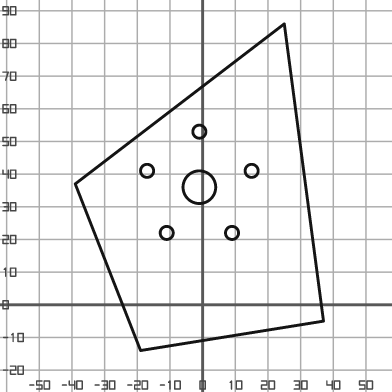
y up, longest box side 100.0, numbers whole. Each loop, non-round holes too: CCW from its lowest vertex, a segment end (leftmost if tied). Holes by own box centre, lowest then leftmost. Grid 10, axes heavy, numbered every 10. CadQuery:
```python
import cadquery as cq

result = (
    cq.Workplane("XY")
    .moveTo(-19.0, -14.0)
    .lineTo(37.0, -5.0)
    .lineTo(25.0, 86.0)
    .lineTo(-39.0, 37.0)
    .close()
    .moveTo(-11.0, 22.0)
    .circle(2.0)
    .moveTo(9.0, 22.0)
    .circle(2.0)
    .moveTo(-1.0, 36.0)
    .circle(5.0)
    .moveTo(-17.0, 41.0)
    .circle(2.0)
    .moveTo(15.0, 41.0)
    .circle(2.0)
    .moveTo(-1.0, 53.0)
    .circle(2.0)
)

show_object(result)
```